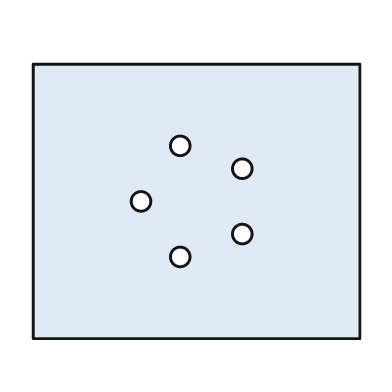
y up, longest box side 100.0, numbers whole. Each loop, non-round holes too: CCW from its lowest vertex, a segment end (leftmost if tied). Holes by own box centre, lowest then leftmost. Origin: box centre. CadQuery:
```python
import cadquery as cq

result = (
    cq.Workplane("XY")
    .moveTo(-50.0, -42.0)
    .lineTo(50.0, -42.0)
    .lineTo(50.0, 42.0)
    .lineTo(-50.0, 42.0)
    .close()
    .moveTo(-5.0, -17.0)
    .circle(3.0)
    .moveTo(14.0, -10.0)
    .circle(3.0)
    .moveTo(-17.0, 0.0)
    .circle(3.0)
    .moveTo(14.0, 10.0)
    .circle(3.0)
    .moveTo(-5.0, 17.0)
    .circle(3.0)
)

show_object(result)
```